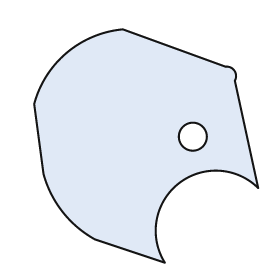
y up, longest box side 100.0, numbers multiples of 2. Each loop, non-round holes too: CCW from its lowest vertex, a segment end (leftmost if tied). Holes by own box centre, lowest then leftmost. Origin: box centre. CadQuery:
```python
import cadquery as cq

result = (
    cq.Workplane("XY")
    .moveTo(8.0, -50.0)
    .threePointArc((14.0, -16.0), (48.0, -18.0))
    .lineTo(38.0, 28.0)
    .threePointArc((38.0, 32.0), (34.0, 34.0))
    .lineTo(-10.0, 50.0)
    .threePointArc((-34.0, 40.0), (-48.0, 18.0))
    .lineTo(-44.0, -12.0)
    .threePointArc((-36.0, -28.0), (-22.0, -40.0))
    .close()
    .moveTo(20.0, 4.0)
    .circle(6.0)
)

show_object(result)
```